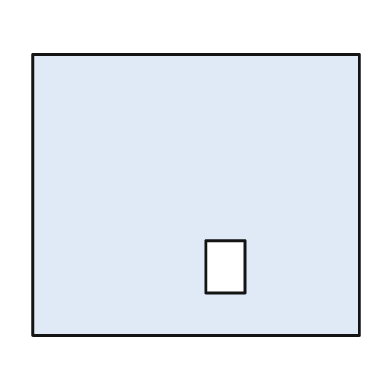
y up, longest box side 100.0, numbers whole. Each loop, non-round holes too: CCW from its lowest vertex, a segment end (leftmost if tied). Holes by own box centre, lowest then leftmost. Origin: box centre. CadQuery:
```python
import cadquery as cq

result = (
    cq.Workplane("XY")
    .moveTo(-50.0, -43.0)
    .lineTo(50.0, -43.0)
    .lineTo(50.0, 43.0)
    .lineTo(-50.0, 43.0)
    .close()
    .moveTo(3.0, -30.0)
    .lineTo(15.0, -30.0)
    .lineTo(15.0, -14.0)
    .lineTo(3.0, -14.0)
    .close()
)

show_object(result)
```